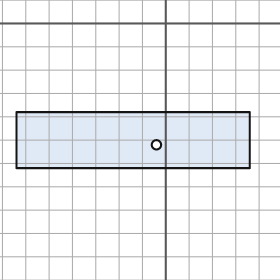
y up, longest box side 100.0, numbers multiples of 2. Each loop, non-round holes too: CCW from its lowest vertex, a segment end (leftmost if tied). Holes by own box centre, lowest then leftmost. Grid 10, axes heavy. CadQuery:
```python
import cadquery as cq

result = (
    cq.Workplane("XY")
    .moveTo(-64.0, -62.0)
    .lineTo(36.0, -62.0)
    .lineTo(36.0, -38.0)
    .lineTo(-64.0, -38.0)
    .close()
    .moveTo(-4.0, -52.0)
    .circle(2.0)
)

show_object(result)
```